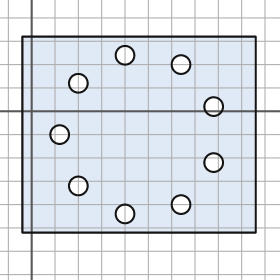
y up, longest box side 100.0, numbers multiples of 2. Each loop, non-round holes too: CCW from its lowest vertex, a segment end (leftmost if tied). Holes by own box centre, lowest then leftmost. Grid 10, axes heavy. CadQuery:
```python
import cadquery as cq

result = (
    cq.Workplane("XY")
    .moveTo(-4.0, -52.0)
    .lineTo(96.0, -52.0)
    .lineTo(96.0, 32.0)
    .lineTo(-4.0, 32.0)
    .close()
    .moveTo(40.0, -44.0)
    .circle(4.0)
    .moveTo(64.0, -40.0)
    .circle(4.0)
    .moveTo(20.0, -32.0)
    .circle(4.0)
    .moveTo(78.0, -22.0)
    .circle(4.0)
    .moveTo(12.0, -10.0)
    .circle(4.0)
    .moveTo(78.0, 2.0)
    .circle(4.0)
    .moveTo(20.0, 12.0)
    .circle(4.0)
    .moveTo(64.0, 20.0)
    .circle(4.0)
    .moveTo(40.0, 24.0)
    .circle(4.0)
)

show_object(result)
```